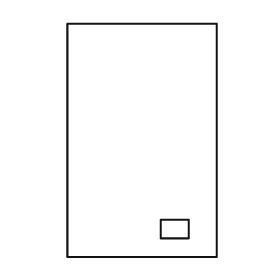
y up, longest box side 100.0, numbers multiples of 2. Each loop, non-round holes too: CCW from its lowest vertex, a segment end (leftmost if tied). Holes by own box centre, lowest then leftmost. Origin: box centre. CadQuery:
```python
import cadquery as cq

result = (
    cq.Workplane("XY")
    .moveTo(-32.0, -50.0)
    .lineTo(32.0, -50.0)
    .lineTo(32.0, 50.0)
    .lineTo(-32.0, 50.0)
    .close()
    .moveTo(8.0, -42.0)
    .lineTo(20.0, -42.0)
    .lineTo(20.0, -34.0)
    .lineTo(8.0, -34.0)
    .close()
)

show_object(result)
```